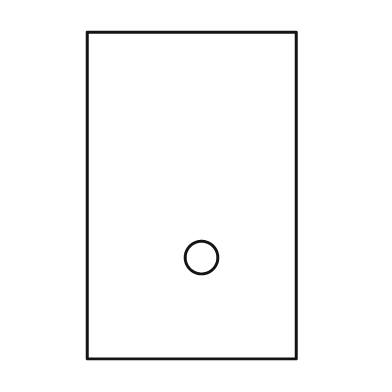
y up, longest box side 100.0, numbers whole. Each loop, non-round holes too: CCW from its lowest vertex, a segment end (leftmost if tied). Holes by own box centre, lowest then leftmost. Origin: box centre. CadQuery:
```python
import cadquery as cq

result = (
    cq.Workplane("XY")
    .moveTo(-32.0, -50.0)
    .lineTo(32.0, -50.0)
    .lineTo(32.0, 50.0)
    .lineTo(-32.0, 50.0)
    .close()
    .moveTo(3.0, -19.0)
    .circle(5.0)
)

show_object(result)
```